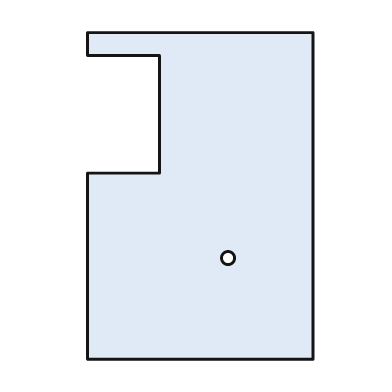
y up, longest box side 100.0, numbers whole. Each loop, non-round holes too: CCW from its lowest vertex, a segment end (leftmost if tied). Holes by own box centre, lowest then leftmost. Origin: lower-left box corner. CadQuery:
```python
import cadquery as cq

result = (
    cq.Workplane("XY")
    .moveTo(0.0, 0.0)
    .lineTo(69.0, 0.0)
    .lineTo(69.0, 100.0)
    .lineTo(0.0, 100.0)
    .lineTo(0.0, 93.0)
    .lineTo(22.0, 93.0)
    .lineTo(22.0, 57.0)
    .lineTo(0.0, 57.0)
    .close()
    .moveTo(43.0, 31.0)
    .circle(2.0)
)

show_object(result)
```